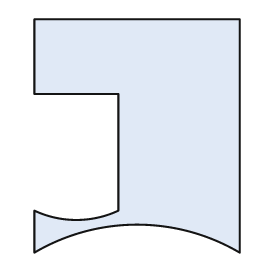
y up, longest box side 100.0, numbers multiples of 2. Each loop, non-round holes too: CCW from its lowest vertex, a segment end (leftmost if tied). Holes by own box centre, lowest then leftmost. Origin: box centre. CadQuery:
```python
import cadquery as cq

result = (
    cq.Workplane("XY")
    .moveTo(-44.0, -50.0)
    .threePointArc((0.0, -38.0), (44.0, -50.0))
    .lineTo(44.0, 50.0)
    .lineTo(-44.0, 50.0)
    .lineTo(-44.0, 18.0)
    .lineTo(-8.0, 18.0)
    .lineTo(-8.0, -32.0)
    .threePointArc((-26.0, -36.0), (-44.0, -32.0))
    .close()
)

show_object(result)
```